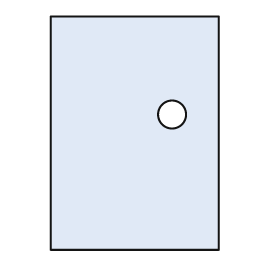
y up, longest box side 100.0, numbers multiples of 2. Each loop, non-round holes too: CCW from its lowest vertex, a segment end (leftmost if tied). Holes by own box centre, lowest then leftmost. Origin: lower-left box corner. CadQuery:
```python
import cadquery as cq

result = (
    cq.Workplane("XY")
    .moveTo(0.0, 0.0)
    .lineTo(72.0, 0.0)
    .lineTo(72.0, 100.0)
    .lineTo(0.0, 100.0)
    .close()
    .moveTo(52.0, 58.0)
    .circle(6.0)
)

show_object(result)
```